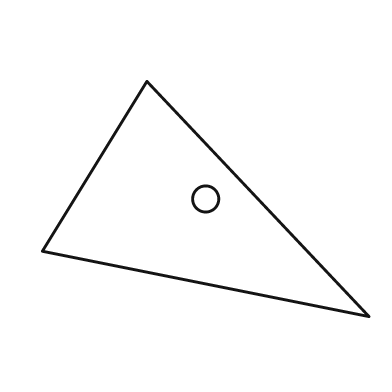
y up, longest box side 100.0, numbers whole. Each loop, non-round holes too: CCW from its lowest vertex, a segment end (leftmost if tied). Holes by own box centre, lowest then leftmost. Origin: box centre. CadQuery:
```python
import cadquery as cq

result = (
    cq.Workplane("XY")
    .moveTo(50.0, -36.0)
    .lineTo(-18.0, 36.0)
    .lineTo(-50.0, -16.0)
    .close()
    .moveTo(0.0, 0.0)
    .circle(4.0)
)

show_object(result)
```